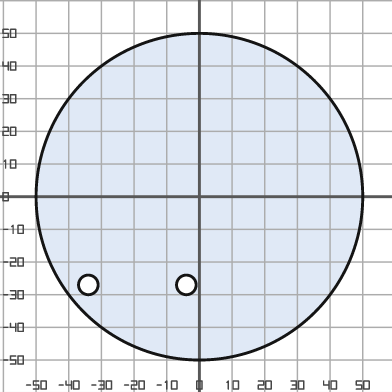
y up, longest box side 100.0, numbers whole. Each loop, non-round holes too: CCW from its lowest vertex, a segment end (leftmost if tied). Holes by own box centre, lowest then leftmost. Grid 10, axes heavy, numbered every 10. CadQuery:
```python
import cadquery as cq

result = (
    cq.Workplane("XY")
    .moveTo(0.0, 0.0)
    .circle(50.0)
    .moveTo(-34.0, -27.0)
    .circle(3.0)
    .moveTo(-4.0, -27.0)
    .circle(3.0)
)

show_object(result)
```